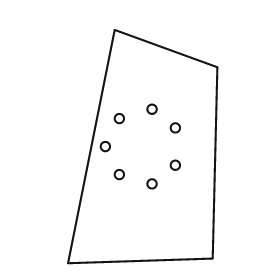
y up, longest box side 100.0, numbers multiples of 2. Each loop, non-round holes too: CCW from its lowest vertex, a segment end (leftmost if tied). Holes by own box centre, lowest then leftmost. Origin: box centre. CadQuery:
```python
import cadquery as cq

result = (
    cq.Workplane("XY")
    .moveTo(-32.0, -50.0)
    .lineTo(30.0, -48.0)
    .lineTo(32.0, 34.0)
    .lineTo(-12.0, 50.0)
    .close()
    .moveTo(4.0, -16.0)
    .circle(2.0)
    .moveTo(-10.0, -12.0)
    .circle(2.0)
    .moveTo(14.0, -8.0)
    .circle(2.0)
    .moveTo(-16.0, 0.0)
    .circle(2.0)
    .moveTo(14.0, 8.0)
    .circle(2.0)
    .moveTo(-10.0, 12.0)
    .circle(2.0)
    .moveTo(4.0, 16.0)
    .circle(2.0)
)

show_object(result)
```